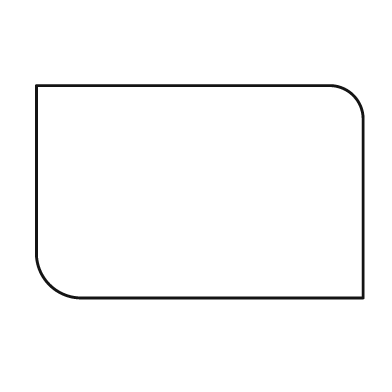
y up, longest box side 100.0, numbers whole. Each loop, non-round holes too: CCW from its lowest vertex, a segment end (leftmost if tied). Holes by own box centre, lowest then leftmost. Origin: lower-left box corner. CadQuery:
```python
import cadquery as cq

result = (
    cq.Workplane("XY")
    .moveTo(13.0, 0.0)
    .lineTo(100.0, 0.0)
    .lineTo(100.0, 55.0)
    .threePointArc((97.0, 62.0), (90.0, 65.0))
    .lineTo(0.0, 65.0)
    .lineTo(0.0, 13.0)
    .threePointArc((4.0, 4.0), (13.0, 0.0))
    .close()
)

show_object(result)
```